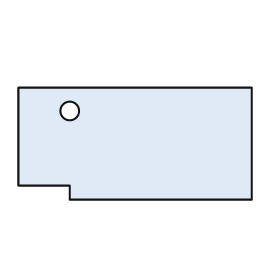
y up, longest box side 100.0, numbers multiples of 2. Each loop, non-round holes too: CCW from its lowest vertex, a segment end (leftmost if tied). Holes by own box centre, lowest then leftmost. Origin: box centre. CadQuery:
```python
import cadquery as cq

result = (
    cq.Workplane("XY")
    .moveTo(-28.0, -24.0)
    .lineTo(50.0, -24.0)
    .lineTo(50.0, 24.0)
    .lineTo(-50.0, 24.0)
    .lineTo(-50.0, -18.0)
    .lineTo(-28.0, -18.0)
    .close()
    .moveTo(-28.0, 14.0)
    .circle(4.0)
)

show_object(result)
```